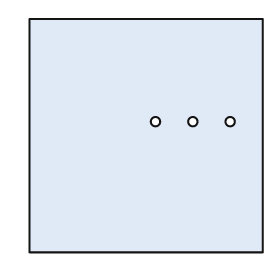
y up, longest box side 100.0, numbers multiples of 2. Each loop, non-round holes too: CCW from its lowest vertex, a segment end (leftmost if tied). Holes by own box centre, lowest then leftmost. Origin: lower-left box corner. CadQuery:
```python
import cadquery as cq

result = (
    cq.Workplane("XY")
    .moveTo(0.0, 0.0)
    .lineTo(100.0, 0.0)
    .lineTo(100.0, 100.0)
    .lineTo(0.0, 100.0)
    .close()
    .moveTo(54.0, 56.0)
    .circle(2.0)
    .moveTo(70.0, 56.0)
    .circle(2.0)
    .moveTo(86.0, 56.0)
    .circle(2.0)
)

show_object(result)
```